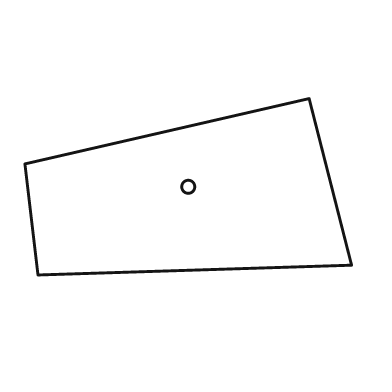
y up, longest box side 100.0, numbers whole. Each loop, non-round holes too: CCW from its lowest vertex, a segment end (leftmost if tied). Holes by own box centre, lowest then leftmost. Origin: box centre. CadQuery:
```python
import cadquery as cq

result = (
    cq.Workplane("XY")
    .moveTo(-46.0, -27.0)
    .lineTo(50.0, -24.0)
    .lineTo(37.0, 27.0)
    .lineTo(-50.0, 7.0)
    .close()
    .moveTo(0.0, 0.0)
    .circle(2.0)
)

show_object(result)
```